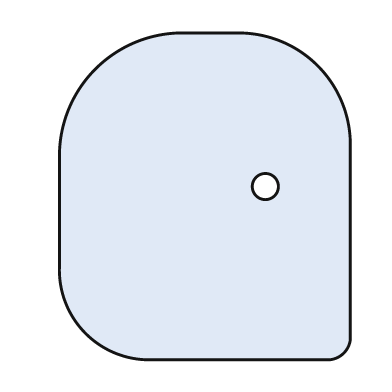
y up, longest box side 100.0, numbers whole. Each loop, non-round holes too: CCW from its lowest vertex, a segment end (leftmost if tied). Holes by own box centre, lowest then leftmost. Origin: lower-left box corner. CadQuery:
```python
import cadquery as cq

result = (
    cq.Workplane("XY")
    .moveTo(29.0, 0.0)
    .lineTo(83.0, 0.0)
    .threePointArc((87.0, 2.0), (89.0, 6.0))
    .lineTo(89.0, 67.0)
    .threePointArc((79.0, 90.0), (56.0, 100.0))
    .lineTo(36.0, 100.0)
    .threePointArc((11.0, 89.0), (0.0, 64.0))
    .lineTo(0.0, 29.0)
    .threePointArc((8.0, 8.0), (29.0, 0.0))
    .close()
    .moveTo(63.0, 53.0)
    .circle(4.0)
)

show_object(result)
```